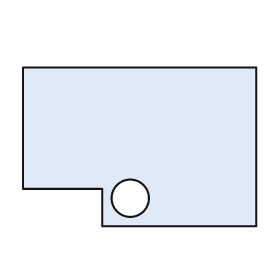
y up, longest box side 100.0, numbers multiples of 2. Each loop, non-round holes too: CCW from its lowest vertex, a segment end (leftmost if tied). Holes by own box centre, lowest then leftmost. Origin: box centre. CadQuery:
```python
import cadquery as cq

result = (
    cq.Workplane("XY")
    .moveTo(-16.0, -34.0)
    .lineTo(50.0, -34.0)
    .lineTo(50.0, 34.0)
    .lineTo(-50.0, 34.0)
    .lineTo(-50.0, -18.0)
    .lineTo(-16.0, -18.0)
    .close()
    .moveTo(-4.0, -22.0)
    .circle(8.0)
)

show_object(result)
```